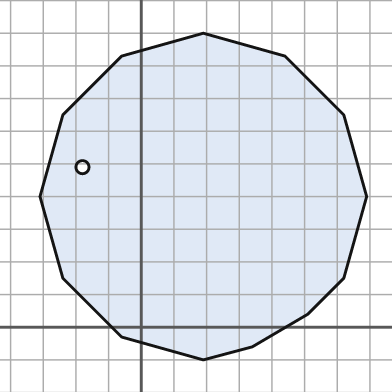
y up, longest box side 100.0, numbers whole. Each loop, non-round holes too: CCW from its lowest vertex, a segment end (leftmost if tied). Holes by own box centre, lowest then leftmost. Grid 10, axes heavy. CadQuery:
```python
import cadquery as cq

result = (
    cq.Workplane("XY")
    .moveTo(19.0, -10.0)
    .lineTo(34.0, -6.0)
    .lineTo(51.0, 4.0)
    .lineTo(62.0, 15.0)
    .lineTo(69.0, 40.0)
    .lineTo(62.0, 65.0)
    .lineTo(44.0, 83.0)
    .lineTo(19.0, 90.0)
    .lineTo(-6.0, 83.0)
    .lineTo(-24.0, 65.0)
    .lineTo(-31.0, 40.0)
    .lineTo(-24.0, 15.0)
    .lineTo(-6.0, -3.0)
    .close()
    .moveTo(-18.0, 49.0)
    .circle(2.0)
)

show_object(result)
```